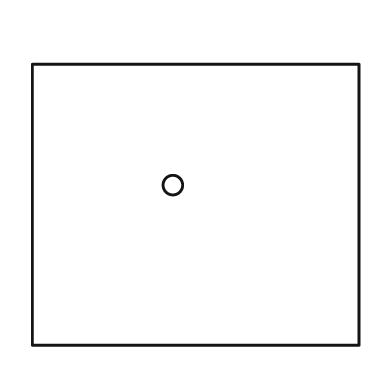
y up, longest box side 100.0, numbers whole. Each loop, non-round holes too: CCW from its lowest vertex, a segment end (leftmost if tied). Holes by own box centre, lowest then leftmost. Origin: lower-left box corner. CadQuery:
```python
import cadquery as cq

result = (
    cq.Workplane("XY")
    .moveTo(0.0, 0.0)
    .lineTo(100.0, 0.0)
    .lineTo(100.0, 86.0)
    .lineTo(0.0, 86.0)
    .close()
    .moveTo(43.0, 49.0)
    .circle(3.0)
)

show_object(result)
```